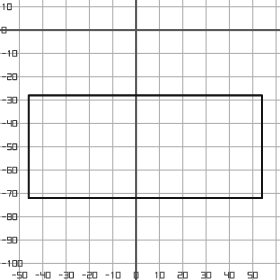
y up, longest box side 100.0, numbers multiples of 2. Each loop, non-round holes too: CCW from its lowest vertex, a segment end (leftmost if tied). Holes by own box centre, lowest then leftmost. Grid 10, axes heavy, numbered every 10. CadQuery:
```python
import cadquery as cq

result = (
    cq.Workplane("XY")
    .moveTo(-46.0, -72.0)
    .lineTo(54.0, -72.0)
    .lineTo(54.0, -28.0)
    .lineTo(-46.0, -28.0)
    .close()
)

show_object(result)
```